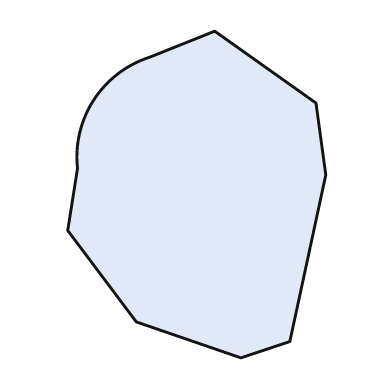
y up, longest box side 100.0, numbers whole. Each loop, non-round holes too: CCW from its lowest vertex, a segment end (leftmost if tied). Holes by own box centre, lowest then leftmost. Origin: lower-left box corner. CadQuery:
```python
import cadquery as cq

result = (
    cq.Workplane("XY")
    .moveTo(53.0, 0.0)
    .lineTo(68.0, 5.0)
    .lineTo(79.0, 56.0)
    .lineTo(76.0, 78.0)
    .lineTo(45.0, 100.0)
    .lineTo(25.0, 92.0)
    .threePointArc((8.0, 79.0), (3.0, 58.0))
    .lineTo(0.0, 39.0)
    .lineTo(21.0, 11.0)
    .close()
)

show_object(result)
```